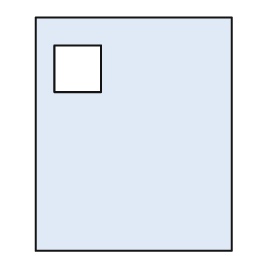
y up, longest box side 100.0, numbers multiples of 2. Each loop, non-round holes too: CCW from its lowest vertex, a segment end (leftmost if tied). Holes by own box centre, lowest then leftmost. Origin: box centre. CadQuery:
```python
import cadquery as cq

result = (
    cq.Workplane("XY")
    .moveTo(-42.0, -50.0)
    .lineTo(42.0, -50.0)
    .lineTo(42.0, 50.0)
    .lineTo(-42.0, 50.0)
    .close()
    .moveTo(-34.0, 18.0)
    .lineTo(-14.0, 18.0)
    .lineTo(-14.0, 38.0)
    .lineTo(-34.0, 38.0)
    .close()
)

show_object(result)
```